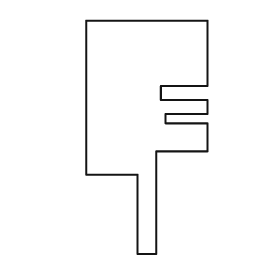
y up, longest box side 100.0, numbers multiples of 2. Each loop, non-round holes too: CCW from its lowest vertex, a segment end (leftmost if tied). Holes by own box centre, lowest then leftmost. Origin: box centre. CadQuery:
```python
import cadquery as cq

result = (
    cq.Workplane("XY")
    .moveTo(-4.0, -50.0)
    .lineTo(4.0, -50.0)
    .lineTo(4.0, -6.0)
    .lineTo(26.0, -6.0)
    .lineTo(26.0, 6.0)
    .lineTo(8.0, 6.0)
    .lineTo(8.0, 10.0)
    .lineTo(26.0, 10.0)
    .lineTo(26.0, 16.0)
    .lineTo(6.0, 16.0)
    .lineTo(6.0, 22.0)
    .lineTo(26.0, 22.0)
    .lineTo(26.0, 50.0)
    .lineTo(-26.0, 50.0)
    .lineTo(-26.0, -16.0)
    .lineTo(-4.0, -16.0)
    .close()
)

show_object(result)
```